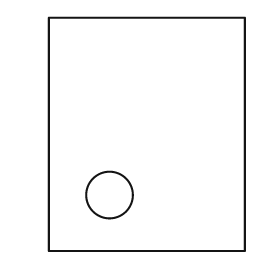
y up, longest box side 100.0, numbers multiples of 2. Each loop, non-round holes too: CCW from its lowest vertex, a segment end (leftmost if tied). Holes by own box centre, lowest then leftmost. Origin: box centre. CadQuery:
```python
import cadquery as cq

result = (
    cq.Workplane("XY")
    .moveTo(-42.0, -50.0)
    .lineTo(42.0, -50.0)
    .lineTo(42.0, 50.0)
    .lineTo(-42.0, 50.0)
    .close()
    .moveTo(-16.0, -26.0)
    .circle(10.0)
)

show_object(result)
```